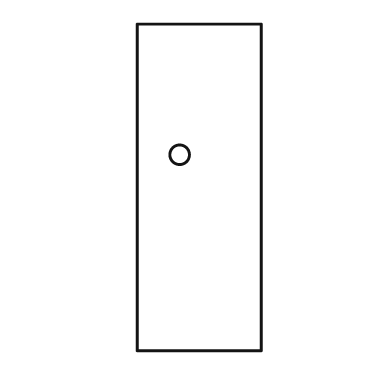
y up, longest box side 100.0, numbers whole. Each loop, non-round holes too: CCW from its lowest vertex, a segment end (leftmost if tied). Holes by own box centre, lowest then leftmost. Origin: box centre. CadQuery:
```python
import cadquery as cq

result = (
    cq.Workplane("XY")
    .moveTo(-19.0, -50.0)
    .lineTo(19.0, -50.0)
    .lineTo(19.0, 50.0)
    .lineTo(-19.0, 50.0)
    .close()
    .moveTo(-6.0, 10.0)
    .circle(3.0)
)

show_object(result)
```